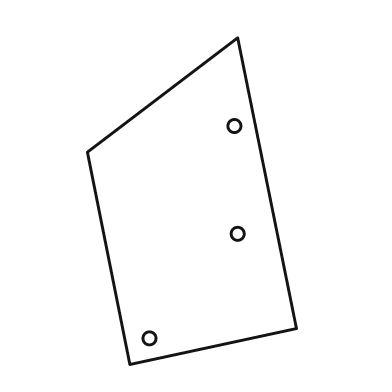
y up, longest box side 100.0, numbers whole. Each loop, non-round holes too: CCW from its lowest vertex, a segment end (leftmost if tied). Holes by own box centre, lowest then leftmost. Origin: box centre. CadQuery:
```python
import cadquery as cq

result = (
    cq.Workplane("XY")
    .moveTo(-19.0, -50.0)
    .lineTo(32.0, -39.0)
    .lineTo(14.0, 50.0)
    .lineTo(-32.0, 15.0)
    .close()
    .moveTo(-13.0, -42.0)
    .circle(2.0)
    .moveTo(14.0, -10.0)
    .circle(2.0)
    .moveTo(13.0, 23.0)
    .circle(2.0)
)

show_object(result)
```